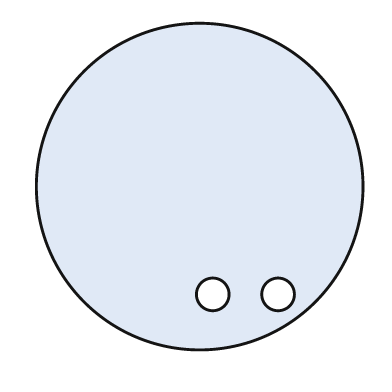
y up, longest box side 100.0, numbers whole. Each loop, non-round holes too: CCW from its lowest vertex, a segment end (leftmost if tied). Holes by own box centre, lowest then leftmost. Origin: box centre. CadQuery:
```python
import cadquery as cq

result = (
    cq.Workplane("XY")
    .moveTo(0.0, 0.0)
    .circle(50.0)
    .moveTo(4.0, -33.0)
    .circle(5.0)
    .moveTo(24.0, -33.0)
    .circle(5.0)
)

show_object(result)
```